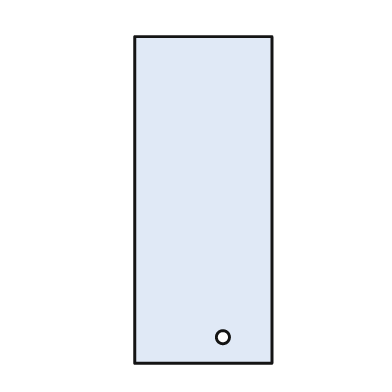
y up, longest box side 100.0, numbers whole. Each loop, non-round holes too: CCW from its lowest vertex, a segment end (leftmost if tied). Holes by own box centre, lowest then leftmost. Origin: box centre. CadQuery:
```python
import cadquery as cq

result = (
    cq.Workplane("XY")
    .moveTo(-21.0, -50.0)
    .lineTo(21.0, -50.0)
    .lineTo(21.0, 50.0)
    .lineTo(-21.0, 50.0)
    .close()
    .moveTo(6.0, -42.0)
    .circle(2.0)
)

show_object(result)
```